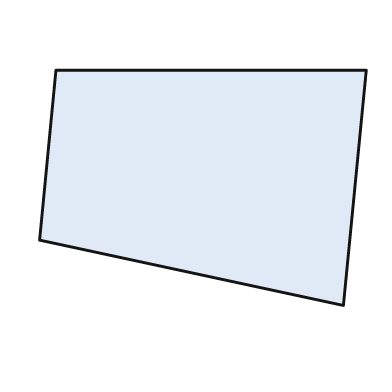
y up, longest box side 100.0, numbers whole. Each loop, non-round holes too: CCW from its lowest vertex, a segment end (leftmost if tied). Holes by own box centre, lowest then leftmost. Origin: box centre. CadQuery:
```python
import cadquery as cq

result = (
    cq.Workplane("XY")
    .moveTo(43.0, -36.0)
    .lineTo(50.0, 36.0)
    .lineTo(-45.0, 36.0)
    .lineTo(-50.0, -16.0)
    .close()
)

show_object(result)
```